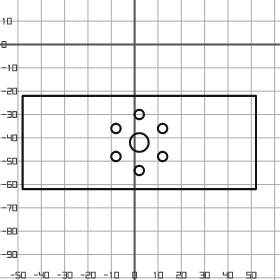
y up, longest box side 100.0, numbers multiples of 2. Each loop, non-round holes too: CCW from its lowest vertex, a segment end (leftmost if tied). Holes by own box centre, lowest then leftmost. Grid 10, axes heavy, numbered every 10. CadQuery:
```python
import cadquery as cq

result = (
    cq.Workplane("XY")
    .moveTo(-48.0, -62.0)
    .lineTo(52.0, -62.0)
    .lineTo(52.0, -22.0)
    .lineTo(-48.0, -22.0)
    .close()
    .moveTo(2.0, -54.0)
    .circle(2.0)
    .moveTo(-8.0, -48.0)
    .circle(2.0)
    .moveTo(12.0, -48.0)
    .circle(2.0)
    .moveTo(2.0, -42.0)
    .circle(4.0)
    .moveTo(-8.0, -36.0)
    .circle(2.0)
    .moveTo(12.0, -36.0)
    .circle(2.0)
    .moveTo(2.0, -30.0)
    .circle(2.0)
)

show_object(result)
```